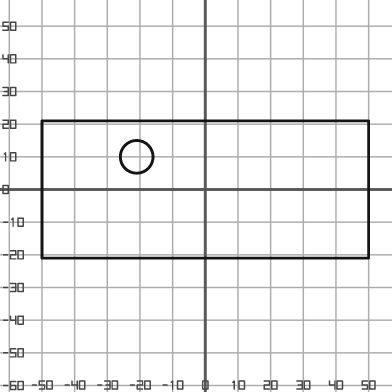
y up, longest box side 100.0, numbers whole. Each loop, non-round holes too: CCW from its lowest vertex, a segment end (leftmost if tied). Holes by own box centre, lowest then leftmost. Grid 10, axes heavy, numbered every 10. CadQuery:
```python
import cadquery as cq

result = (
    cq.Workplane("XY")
    .moveTo(-50.0, -21.0)
    .lineTo(50.0, -21.0)
    .lineTo(50.0, 21.0)
    .lineTo(-50.0, 21.0)
    .close()
    .moveTo(-21.0, 10.0)
    .circle(5.0)
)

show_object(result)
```